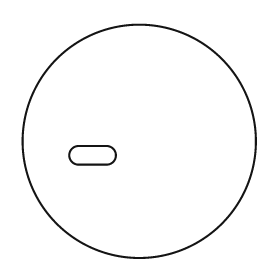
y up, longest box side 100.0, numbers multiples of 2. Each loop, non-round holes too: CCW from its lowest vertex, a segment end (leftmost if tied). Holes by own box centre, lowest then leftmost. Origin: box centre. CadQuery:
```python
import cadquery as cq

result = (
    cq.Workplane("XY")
    .moveTo(0.0, 0.0)
    .circle(50.0)
    .moveTo(-26.0, -10.0)
    .lineTo(-14.0, -10.0)
    .threePointArc((-10.0, -6.0), (-14.0, -2.0))
    .lineTo(-26.0, -2.0)
    .threePointArc((-30.0, -6.0), (-26.0, -10.0))
    .close()
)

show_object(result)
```